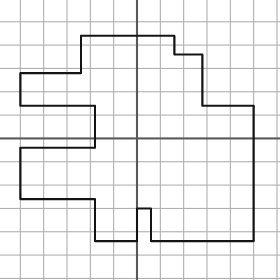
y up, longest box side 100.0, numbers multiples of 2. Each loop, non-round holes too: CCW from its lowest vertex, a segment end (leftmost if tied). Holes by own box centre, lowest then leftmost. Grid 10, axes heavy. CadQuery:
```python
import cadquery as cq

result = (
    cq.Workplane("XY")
    .moveTo(-18.0, -44.0)
    .lineTo(0.0, -44.0)
    .lineTo(0.0, -30.0)
    .lineTo(6.0, -30.0)
    .lineTo(6.0, -44.0)
    .lineTo(50.0, -44.0)
    .lineTo(50.0, 14.0)
    .lineTo(28.0, 14.0)
    .lineTo(28.0, 36.0)
    .lineTo(16.0, 36.0)
    .lineTo(16.0, 44.0)
    .lineTo(-24.0, 44.0)
    .lineTo(-24.0, 28.0)
    .lineTo(-50.0, 28.0)
    .lineTo(-50.0, 14.0)
    .lineTo(-18.0, 14.0)
    .lineTo(-18.0, -4.0)
    .lineTo(-50.0, -4.0)
    .lineTo(-50.0, -26.0)
    .lineTo(-18.0, -26.0)
    .close()
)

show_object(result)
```